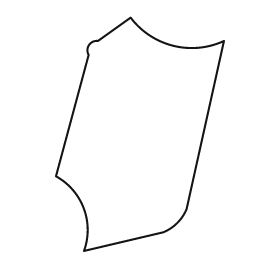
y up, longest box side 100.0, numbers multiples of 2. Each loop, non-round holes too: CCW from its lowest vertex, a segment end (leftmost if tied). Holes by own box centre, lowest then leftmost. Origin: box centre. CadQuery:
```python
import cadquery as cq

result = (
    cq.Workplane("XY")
    .moveTo(-24.0, -50.0)
    .lineTo(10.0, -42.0)
    .threePointArc((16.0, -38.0), (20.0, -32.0))
    .lineTo(36.0, 40.0)
    .threePointArc((14.0, 38.0), (-4.0, 50.0))
    .lineTo(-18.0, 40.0)
    .threePointArc((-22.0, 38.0), (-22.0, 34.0))
    .lineTo(-36.0, -18.0)
    .threePointArc((-24.0, -32.0), (-24.0, -50.0))
    .close()
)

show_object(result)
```